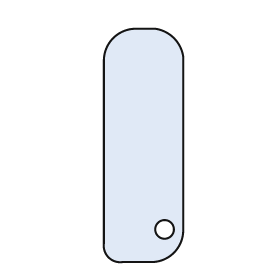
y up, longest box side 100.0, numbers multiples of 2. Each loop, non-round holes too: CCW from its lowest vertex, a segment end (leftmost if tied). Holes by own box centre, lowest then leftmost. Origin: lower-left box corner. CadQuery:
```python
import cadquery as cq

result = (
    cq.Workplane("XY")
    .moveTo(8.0, 0.0)
    .lineTo(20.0, 0.0)
    .threePointArc((30.0, 4.0), (34.0, 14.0))
    .lineTo(34.0, 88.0)
    .threePointArc((30.0, 96.0), (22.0, 100.0))
    .lineTo(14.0, 100.0)
    .threePointArc((4.0, 96.0), (0.0, 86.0))
    .lineTo(0.0, 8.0)
    .threePointArc((2.0, 2.0), (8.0, 0.0))
    .close()
    .moveTo(26.0, 14.0)
    .circle(4.0)
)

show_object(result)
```